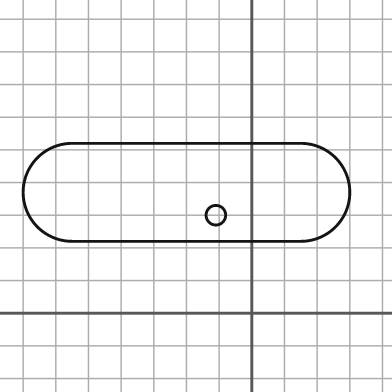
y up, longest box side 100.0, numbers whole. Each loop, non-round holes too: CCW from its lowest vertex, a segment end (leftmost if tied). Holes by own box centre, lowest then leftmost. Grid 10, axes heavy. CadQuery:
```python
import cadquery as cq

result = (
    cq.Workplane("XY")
    .moveTo(-55.0, 22.0)
    .lineTo(15.0, 22.0)
    .threePointArc((30.0, 37.0), (15.0, 52.0))
    .lineTo(-55.0, 52.0)
    .threePointArc((-70.0, 37.0), (-55.0, 22.0))
    .close()
    .moveTo(-11.0, 30.0)
    .circle(3.0)
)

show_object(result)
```